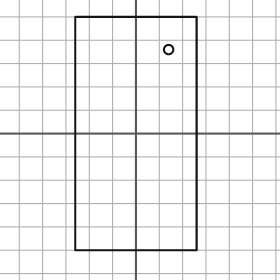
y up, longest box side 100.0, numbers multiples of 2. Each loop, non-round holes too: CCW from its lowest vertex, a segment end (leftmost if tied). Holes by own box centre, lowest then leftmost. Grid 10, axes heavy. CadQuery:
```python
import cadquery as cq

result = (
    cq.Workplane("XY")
    .moveTo(-26.0, -50.0)
    .lineTo(26.0, -50.0)
    .lineTo(26.0, 50.0)
    .lineTo(-26.0, 50.0)
    .close()
    .moveTo(14.0, 36.0)
    .circle(2.0)
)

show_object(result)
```